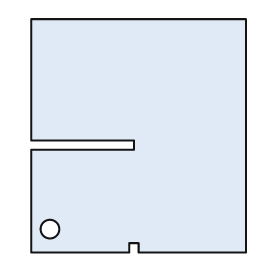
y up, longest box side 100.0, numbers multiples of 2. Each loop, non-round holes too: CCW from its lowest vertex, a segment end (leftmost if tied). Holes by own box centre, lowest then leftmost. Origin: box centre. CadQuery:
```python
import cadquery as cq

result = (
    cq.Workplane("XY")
    .moveTo(-46.0, -50.0)
    .lineTo(-4.0, -50.0)
    .lineTo(-4.0, -46.0)
    .lineTo(0.0, -46.0)
    .lineTo(0.0, -50.0)
    .lineTo(46.0, -50.0)
    .lineTo(46.0, 50.0)
    .lineTo(-46.0, 50.0)
    .lineTo(-46.0, -2.0)
    .lineTo(-2.0, -2.0)
    .lineTo(-2.0, -6.0)
    .lineTo(-46.0, -6.0)
    .close()
    .moveTo(-38.0, -40.0)
    .circle(4.0)
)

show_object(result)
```